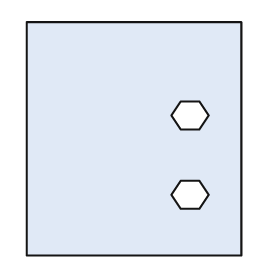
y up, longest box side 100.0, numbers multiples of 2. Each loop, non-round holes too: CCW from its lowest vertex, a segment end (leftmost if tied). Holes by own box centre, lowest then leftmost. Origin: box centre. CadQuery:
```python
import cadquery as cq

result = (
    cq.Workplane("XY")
    .moveTo(-46.0, -50.0)
    .lineTo(46.0, -50.0)
    .lineTo(46.0, 50.0)
    .lineTo(-46.0, 50.0)
    .close()
    .moveTo(20.0, -30.0)
    .lineTo(28.0, -30.0)
    .lineTo(32.0, -24.0)
    .lineTo(28.0, -18.0)
    .lineTo(20.0, -18.0)
    .lineTo(16.0, -24.0)
    .close()
    .moveTo(20.0, 4.0)
    .lineTo(28.0, 4.0)
    .lineTo(32.0, 10.0)
    .lineTo(28.0, 16.0)
    .lineTo(20.0, 16.0)
    .lineTo(16.0, 10.0)
    .close()
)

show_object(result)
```